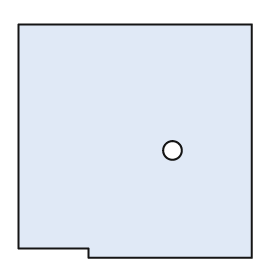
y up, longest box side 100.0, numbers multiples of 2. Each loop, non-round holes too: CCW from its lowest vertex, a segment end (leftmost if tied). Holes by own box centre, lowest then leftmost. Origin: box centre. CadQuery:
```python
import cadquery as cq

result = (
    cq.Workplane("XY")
    .moveTo(-20.0, -50.0)
    .lineTo(50.0, -50.0)
    .lineTo(50.0, 50.0)
    .lineTo(-50.0, 50.0)
    .lineTo(-50.0, -46.0)
    .lineTo(-20.0, -46.0)
    .close()
    .moveTo(16.0, -4.0)
    .circle(4.0)
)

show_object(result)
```